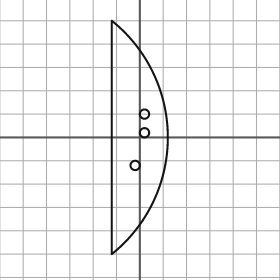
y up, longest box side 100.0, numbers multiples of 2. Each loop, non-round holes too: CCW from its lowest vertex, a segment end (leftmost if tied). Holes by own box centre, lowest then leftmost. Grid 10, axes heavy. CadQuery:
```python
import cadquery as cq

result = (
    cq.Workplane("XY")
    .moveTo(-12.0, -50.0)
    .threePointArc((12.0, 0.0), (-12.0, 50.0))
    .close()
    .moveTo(-2.0, -12.0)
    .circle(2.0)
    .moveTo(2.0, 2.0)
    .circle(2.0)
    .moveTo(2.0, 10.0)
    .circle(2.0)
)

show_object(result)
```